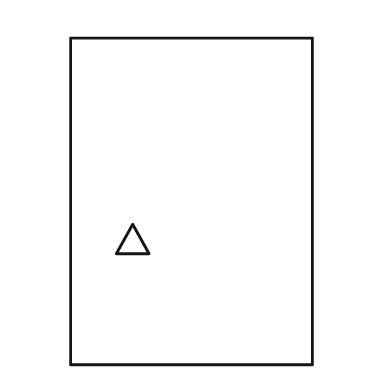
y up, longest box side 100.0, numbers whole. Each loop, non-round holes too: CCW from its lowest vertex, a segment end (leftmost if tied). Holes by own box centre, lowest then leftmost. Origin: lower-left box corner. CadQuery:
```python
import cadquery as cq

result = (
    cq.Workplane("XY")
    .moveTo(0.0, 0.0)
    .lineTo(74.0, 0.0)
    .lineTo(74.0, 100.0)
    .lineTo(0.0, 100.0)
    .close()
    .moveTo(14.0, 34.0)
    .lineTo(24.0, 34.0)
    .lineTo(19.0, 43.0)
    .close()
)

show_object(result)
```